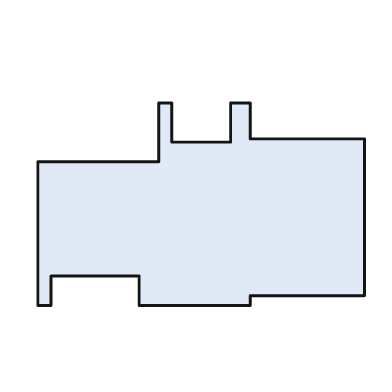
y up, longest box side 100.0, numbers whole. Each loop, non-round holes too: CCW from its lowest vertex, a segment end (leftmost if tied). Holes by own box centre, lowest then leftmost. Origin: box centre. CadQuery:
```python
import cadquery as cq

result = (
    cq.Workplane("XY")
    .moveTo(-50.0, -31.0)
    .lineTo(-46.0, -31.0)
    .lineTo(-46.0, -22.0)
    .lineTo(-19.0, -22.0)
    .lineTo(-19.0, -31.0)
    .lineTo(15.0, -31.0)
    .lineTo(15.0, -28.0)
    .lineTo(50.0, -28.0)
    .lineTo(50.0, 20.0)
    .lineTo(15.0, 20.0)
    .lineTo(15.0, 31.0)
    .lineTo(9.0, 31.0)
    .lineTo(9.0, 19.0)
    .lineTo(-9.0, 19.0)
    .lineTo(-9.0, 31.0)
    .lineTo(-13.0, 31.0)
    .lineTo(-13.0, 13.0)
    .lineTo(-50.0, 13.0)
    .close()
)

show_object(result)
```